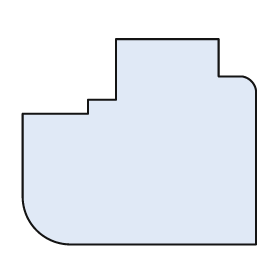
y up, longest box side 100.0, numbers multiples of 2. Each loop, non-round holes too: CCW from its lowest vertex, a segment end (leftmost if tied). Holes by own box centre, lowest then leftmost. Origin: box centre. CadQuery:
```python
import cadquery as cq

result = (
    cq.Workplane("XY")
    .moveTo(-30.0, -44.0)
    .lineTo(50.0, -44.0)
    .lineTo(50.0, 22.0)
    .threePointArc((48.0, 26.0), (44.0, 28.0))
    .lineTo(34.0, 28.0)
    .lineTo(34.0, 44.0)
    .lineTo(-10.0, 44.0)
    .lineTo(-10.0, 18.0)
    .lineTo(-22.0, 18.0)
    .lineTo(-22.0, 12.0)
    .lineTo(-50.0, 12.0)
    .lineTo(-50.0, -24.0)
    .threePointArc((-44.0, -38.0), (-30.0, -44.0))
    .close()
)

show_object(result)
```